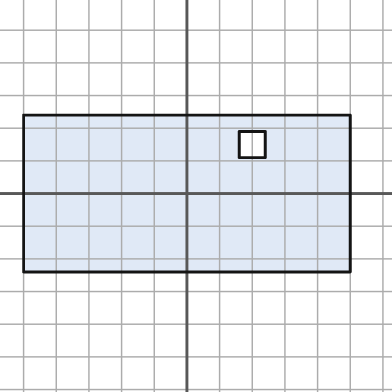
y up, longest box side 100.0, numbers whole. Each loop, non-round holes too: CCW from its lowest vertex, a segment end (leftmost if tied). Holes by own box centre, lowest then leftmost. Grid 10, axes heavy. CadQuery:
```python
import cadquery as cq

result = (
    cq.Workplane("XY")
    .moveTo(-50.0, -24.0)
    .lineTo(50.0, -24.0)
    .lineTo(50.0, 24.0)
    .lineTo(-50.0, 24.0)
    .close()
    .moveTo(16.0, 11.0)
    .lineTo(24.0, 11.0)
    .lineTo(24.0, 19.0)
    .lineTo(16.0, 19.0)
    .close()
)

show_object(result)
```